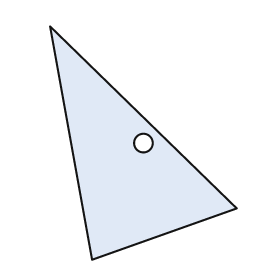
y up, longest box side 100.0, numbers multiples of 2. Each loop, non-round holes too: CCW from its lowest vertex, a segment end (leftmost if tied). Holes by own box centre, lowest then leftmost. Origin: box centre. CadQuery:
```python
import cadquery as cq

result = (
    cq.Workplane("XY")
    .moveTo(-22.0, -50.0)
    .lineTo(40.0, -28.0)
    .lineTo(-40.0, 50.0)
    .close()
    .moveTo(0.0, 0.0)
    .circle(4.0)
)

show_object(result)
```